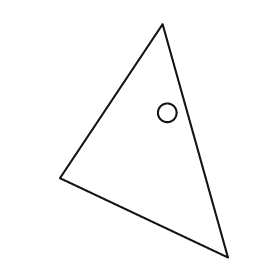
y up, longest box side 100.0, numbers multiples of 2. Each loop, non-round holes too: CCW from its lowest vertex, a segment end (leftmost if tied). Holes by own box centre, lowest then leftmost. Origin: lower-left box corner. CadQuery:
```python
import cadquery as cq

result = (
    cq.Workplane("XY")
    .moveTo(72.0, 0.0)
    .lineTo(44.0, 100.0)
    .lineTo(0.0, 34.0)
    .close()
    .moveTo(46.0, 62.0)
    .circle(4.0)
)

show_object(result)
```